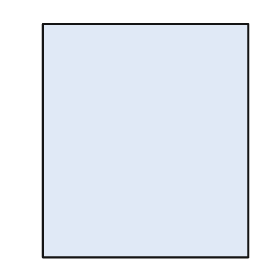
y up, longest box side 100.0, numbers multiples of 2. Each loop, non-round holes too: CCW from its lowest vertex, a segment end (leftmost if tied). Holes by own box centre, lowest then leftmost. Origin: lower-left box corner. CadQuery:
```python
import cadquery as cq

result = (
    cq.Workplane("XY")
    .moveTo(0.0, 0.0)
    .lineTo(88.0, 0.0)
    .lineTo(88.0, 100.0)
    .lineTo(0.0, 100.0)
    .close()
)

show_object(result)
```